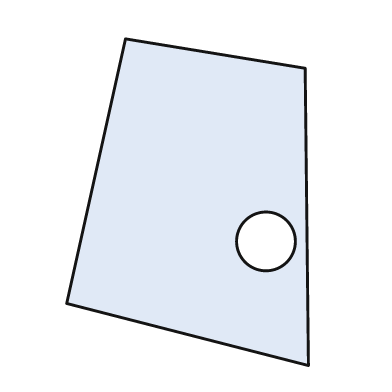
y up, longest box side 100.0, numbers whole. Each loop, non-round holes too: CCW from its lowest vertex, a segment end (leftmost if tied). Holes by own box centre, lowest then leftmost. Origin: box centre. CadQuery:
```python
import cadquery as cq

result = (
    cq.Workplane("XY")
    .moveTo(37.0, -50.0)
    .lineTo(36.0, 41.0)
    .lineTo(-19.0, 50.0)
    .lineTo(-37.0, -31.0)
    .close()
    .moveTo(24.0, -12.0)
    .circle(9.0)
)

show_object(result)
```